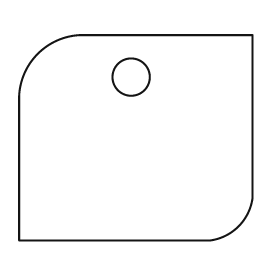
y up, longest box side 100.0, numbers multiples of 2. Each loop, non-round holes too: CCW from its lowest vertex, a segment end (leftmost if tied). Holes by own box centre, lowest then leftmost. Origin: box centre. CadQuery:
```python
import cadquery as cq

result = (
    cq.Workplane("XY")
    .moveTo(-50.0, -44.0)
    .lineTo(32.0, -44.0)
    .threePointArc((44.0, -38.0), (50.0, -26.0))
    .lineTo(50.0, 44.0)
    .lineTo(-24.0, 44.0)
    .threePointArc((-42.0, 36.0), (-50.0, 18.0))
    .close()
    .moveTo(-2.0, 26.0)
    .circle(8.0)
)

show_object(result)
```